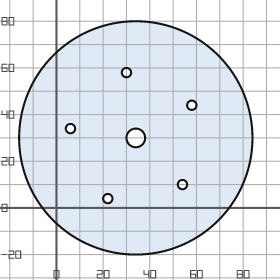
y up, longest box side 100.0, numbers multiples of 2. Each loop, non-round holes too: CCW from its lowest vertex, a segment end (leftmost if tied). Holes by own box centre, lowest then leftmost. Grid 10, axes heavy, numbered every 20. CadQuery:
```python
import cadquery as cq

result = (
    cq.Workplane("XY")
    .moveTo(34.0, 30.0)
    .circle(50.0)
    .moveTo(22.0, 4.0)
    .circle(2.0)
    .moveTo(54.0, 10.0)
    .circle(2.0)
    .moveTo(34.0, 30.0)
    .circle(4.0)
    .moveTo(6.0, 34.0)
    .circle(2.0)
    .moveTo(58.0, 44.0)
    .circle(2.0)
    .moveTo(30.0, 58.0)
    .circle(2.0)
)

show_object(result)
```